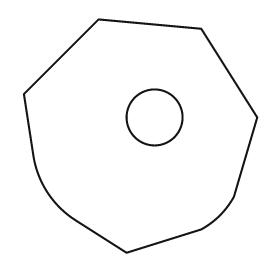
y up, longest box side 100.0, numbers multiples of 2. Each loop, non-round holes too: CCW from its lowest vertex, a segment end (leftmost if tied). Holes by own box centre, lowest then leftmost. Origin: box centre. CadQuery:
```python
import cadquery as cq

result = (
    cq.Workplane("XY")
    .moveTo(-6.0, -50.0)
    .lineTo(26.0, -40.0)
    .threePointArc((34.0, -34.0), (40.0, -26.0))
    .lineTo(50.0, 8.0)
    .lineTo(26.0, 46.0)
    .lineTo(-18.0, 50.0)
    .lineTo(-50.0, 18.0)
    .lineTo(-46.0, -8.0)
    .threePointArc((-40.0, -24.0), (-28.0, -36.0))
    .close()
    .moveTo(6.0, 8.0)
    .circle(12.0)
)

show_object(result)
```